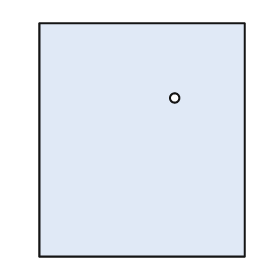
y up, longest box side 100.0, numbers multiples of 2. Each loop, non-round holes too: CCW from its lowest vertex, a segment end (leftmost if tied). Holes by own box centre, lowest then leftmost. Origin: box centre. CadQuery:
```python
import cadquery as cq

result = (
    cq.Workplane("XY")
    .moveTo(-44.0, -50.0)
    .lineTo(44.0, -50.0)
    .lineTo(44.0, 50.0)
    .lineTo(-44.0, 50.0)
    .close()
    .moveTo(14.0, 18.0)
    .circle(2.0)
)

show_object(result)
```